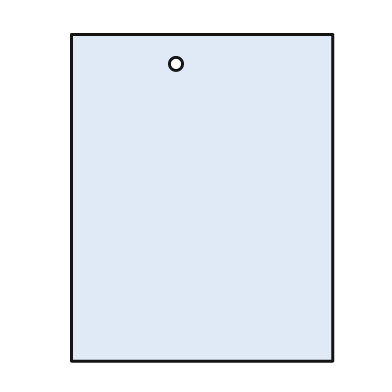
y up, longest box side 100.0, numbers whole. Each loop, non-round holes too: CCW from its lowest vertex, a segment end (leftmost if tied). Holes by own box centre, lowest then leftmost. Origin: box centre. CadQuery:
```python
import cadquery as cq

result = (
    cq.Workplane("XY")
    .moveTo(-40.0, -50.0)
    .lineTo(40.0, -50.0)
    .lineTo(40.0, 50.0)
    .lineTo(-40.0, 50.0)
    .close()
    .moveTo(-8.0, 41.0)
    .circle(2.0)
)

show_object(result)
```